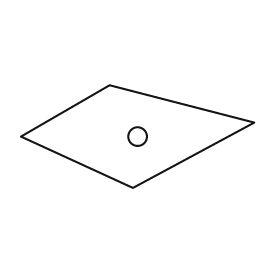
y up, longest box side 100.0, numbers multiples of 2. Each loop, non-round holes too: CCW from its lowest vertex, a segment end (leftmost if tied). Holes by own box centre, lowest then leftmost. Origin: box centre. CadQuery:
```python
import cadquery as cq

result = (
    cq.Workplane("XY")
    .moveTo(-2.0, -22.0)
    .lineTo(50.0, 6.0)
    .lineTo(-12.0, 22.0)
    .lineTo(-50.0, 0.0)
    .close()
    .moveTo(0.0, 0.0)
    .circle(4.0)
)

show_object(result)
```